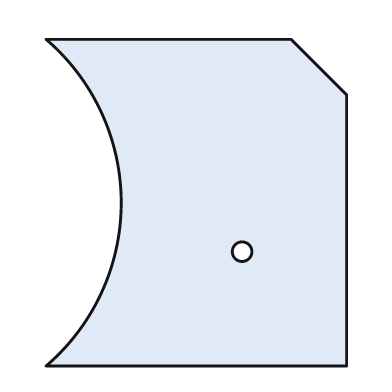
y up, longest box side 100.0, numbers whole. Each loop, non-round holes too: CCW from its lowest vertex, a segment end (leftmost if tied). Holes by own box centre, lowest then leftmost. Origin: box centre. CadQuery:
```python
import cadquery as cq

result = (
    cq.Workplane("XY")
    .moveTo(-46.0, -50.0)
    .lineTo(46.0, -50.0)
    .lineTo(46.0, 33.0)
    .lineTo(29.0, 50.0)
    .lineTo(-46.0, 50.0)
    .threePointArc((-23.0, 0.0), (-46.0, -50.0))
    .close()
    .moveTo(14.0, -15.0)
    .circle(3.0)
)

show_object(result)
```